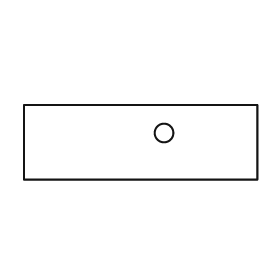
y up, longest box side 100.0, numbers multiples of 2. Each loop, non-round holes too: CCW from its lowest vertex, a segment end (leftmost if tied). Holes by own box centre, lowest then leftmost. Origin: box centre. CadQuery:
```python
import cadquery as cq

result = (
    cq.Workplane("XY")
    .moveTo(-50.0, -16.0)
    .lineTo(50.0, -16.0)
    .lineTo(50.0, 16.0)
    .lineTo(-50.0, 16.0)
    .close()
    .moveTo(10.0, 4.0)
    .circle(4.0)
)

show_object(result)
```